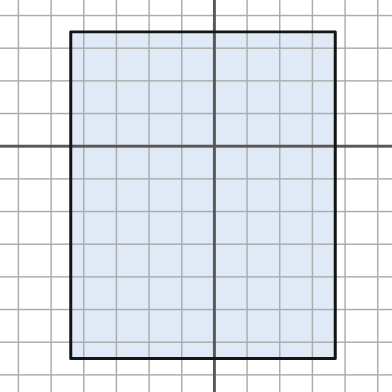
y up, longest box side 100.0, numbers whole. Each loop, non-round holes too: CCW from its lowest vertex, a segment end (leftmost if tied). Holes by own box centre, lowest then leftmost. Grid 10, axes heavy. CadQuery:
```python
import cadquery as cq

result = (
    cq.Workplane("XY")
    .moveTo(-44.0, -65.0)
    .lineTo(37.0, -65.0)
    .lineTo(37.0, 35.0)
    .lineTo(-44.0, 35.0)
    .close()
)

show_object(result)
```